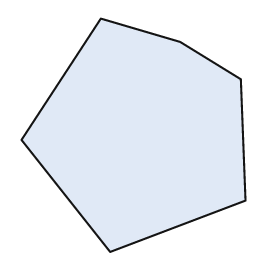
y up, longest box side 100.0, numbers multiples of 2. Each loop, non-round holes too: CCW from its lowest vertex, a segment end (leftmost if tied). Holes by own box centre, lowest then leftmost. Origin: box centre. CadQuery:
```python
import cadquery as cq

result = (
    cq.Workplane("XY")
    .moveTo(-10.0, -50.0)
    .lineTo(48.0, -28.0)
    .lineTo(46.0, 24.0)
    .lineTo(20.0, 40.0)
    .lineTo(-14.0, 50.0)
    .lineTo(-48.0, -2.0)
    .close()
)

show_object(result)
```